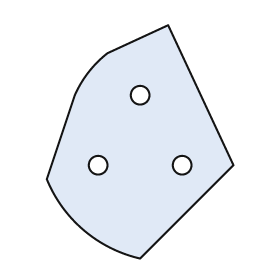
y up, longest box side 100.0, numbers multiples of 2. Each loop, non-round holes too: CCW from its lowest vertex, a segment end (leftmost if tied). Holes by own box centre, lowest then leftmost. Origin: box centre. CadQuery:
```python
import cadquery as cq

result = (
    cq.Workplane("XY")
    .moveTo(0.0, -50.0)
    .lineTo(40.0, -10.0)
    .lineTo(12.0, 50.0)
    .lineTo(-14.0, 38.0)
    .threePointArc((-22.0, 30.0), (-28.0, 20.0))
    .lineTo(-40.0, -16.0)
    .threePointArc((-24.0, -38.0), (0.0, -50.0))
    .close()
    .moveTo(-18.0, -10.0)
    .circle(4.0)
    .moveTo(18.0, -10.0)
    .circle(4.0)
    .moveTo(0.0, 20.0)
    .circle(4.0)
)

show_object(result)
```